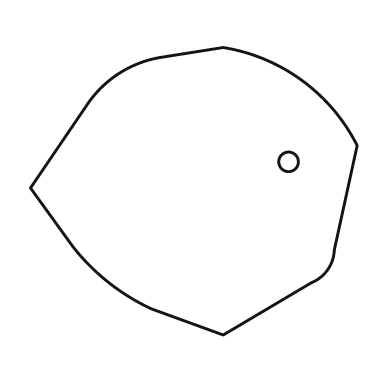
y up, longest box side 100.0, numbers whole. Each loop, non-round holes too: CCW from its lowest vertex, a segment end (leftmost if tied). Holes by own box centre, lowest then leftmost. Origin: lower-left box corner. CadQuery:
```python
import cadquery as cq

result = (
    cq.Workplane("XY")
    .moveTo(59.0, 0.0)
    .lineTo(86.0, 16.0)
    .threePointArc((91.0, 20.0), (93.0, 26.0))
    .lineTo(100.0, 58.0)
    .threePointArc((83.0, 78.0), (59.0, 88.0))
    .lineTo(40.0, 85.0)
    .threePointArc((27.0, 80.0), (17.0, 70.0))
    .lineTo(0.0, 45.0)
    .lineTo(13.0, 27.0)
    .threePointArc((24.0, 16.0), (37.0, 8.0))
    .close()
    .moveTo(79.0, 53.0)
    .circle(3.0)
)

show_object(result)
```